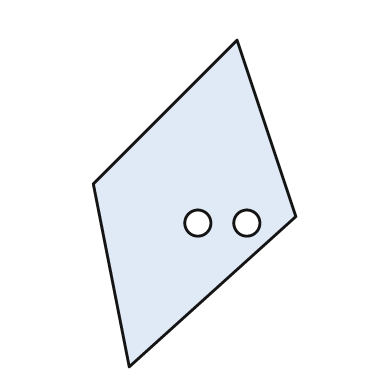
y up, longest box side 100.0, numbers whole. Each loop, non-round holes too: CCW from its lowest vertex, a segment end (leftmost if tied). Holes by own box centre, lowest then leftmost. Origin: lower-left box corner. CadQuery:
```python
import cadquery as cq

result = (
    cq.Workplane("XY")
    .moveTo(11.0, 0.0)
    .lineTo(62.0, 46.0)
    .lineTo(44.0, 100.0)
    .lineTo(0.0, 56.0)
    .close()
    .moveTo(32.0, 44.0)
    .circle(4.0)
    .moveTo(47.0, 44.0)
    .circle(4.0)
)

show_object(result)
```